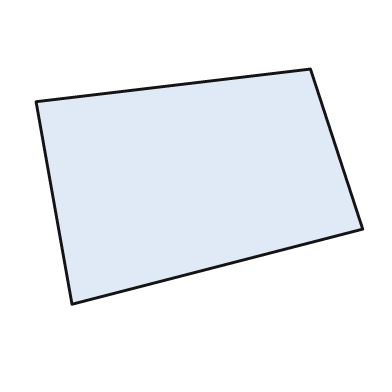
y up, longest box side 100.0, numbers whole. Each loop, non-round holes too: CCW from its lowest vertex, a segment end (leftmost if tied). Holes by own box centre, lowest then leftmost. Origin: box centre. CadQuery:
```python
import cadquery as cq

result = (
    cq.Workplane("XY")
    .moveTo(-39.0, -36.0)
    .lineTo(50.0, -13.0)
    .lineTo(34.0, 36.0)
    .lineTo(-50.0, 26.0)
    .close()
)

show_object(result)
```